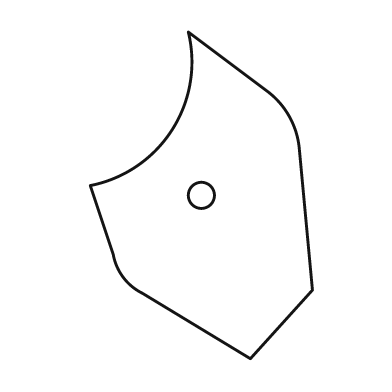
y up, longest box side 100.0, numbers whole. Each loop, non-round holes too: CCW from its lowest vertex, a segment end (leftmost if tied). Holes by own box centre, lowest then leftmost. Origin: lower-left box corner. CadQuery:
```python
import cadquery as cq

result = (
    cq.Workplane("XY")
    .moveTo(49.0, 0.0)
    .lineTo(68.0, 21.0)
    .lineTo(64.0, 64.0)
    .threePointArc((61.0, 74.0), (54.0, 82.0))
    .lineTo(30.0, 100.0)
    .threePointArc((25.0, 70.0), (0.0, 53.0))
    .lineTo(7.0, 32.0)
    .threePointArc((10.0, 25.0), (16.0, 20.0))
    .close()
    .moveTo(34.0, 50.0)
    .circle(4.0)
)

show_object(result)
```